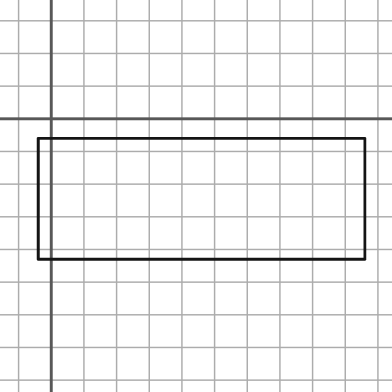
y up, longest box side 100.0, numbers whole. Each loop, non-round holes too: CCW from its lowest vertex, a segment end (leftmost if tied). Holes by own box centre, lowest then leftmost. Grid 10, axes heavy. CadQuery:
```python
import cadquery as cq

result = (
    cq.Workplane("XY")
    .moveTo(-4.0, -43.0)
    .lineTo(96.0, -43.0)
    .lineTo(96.0, -6.0)
    .lineTo(-4.0, -6.0)
    .close()
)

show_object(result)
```